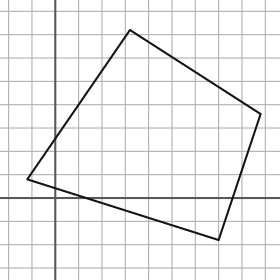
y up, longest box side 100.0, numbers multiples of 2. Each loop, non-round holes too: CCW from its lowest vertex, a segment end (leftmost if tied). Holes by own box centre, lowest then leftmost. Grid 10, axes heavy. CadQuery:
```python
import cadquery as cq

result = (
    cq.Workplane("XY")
    .moveTo(70.0, -18.0)
    .lineTo(88.0, 36.0)
    .lineTo(32.0, 72.0)
    .lineTo(-12.0, 8.0)
    .close()
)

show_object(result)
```